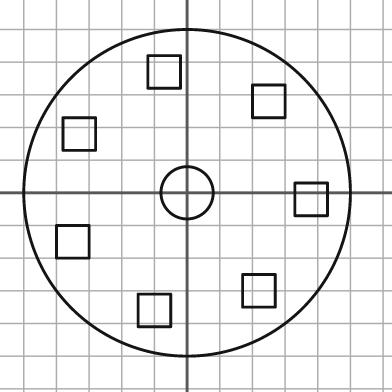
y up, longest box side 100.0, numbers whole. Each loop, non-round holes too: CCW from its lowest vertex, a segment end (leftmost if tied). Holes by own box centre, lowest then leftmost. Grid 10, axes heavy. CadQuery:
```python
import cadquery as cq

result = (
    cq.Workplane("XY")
    .moveTo(0.0, 0.0)
    .circle(50.0)
    .moveTo(-15.0, -41.0)
    .lineTo(-5.0, -41.0)
    .lineTo(-5.0, -31.0)
    .lineTo(-15.0, -31.0)
    .close()
    .moveTo(17.0, -35.0)
    .lineTo(27.0, -35.0)
    .lineTo(27.0, -25.0)
    .lineTo(17.0, -25.0)
    .close()
    .moveTo(-40.0, -20.0)
    .lineTo(-30.0, -20.0)
    .lineTo(-30.0, -10.0)
    .lineTo(-40.0, -10.0)
    .close()
    .moveTo(33.0, -7.0)
    .lineTo(43.0, -7.0)
    .lineTo(43.0, 3.0)
    .lineTo(33.0, 3.0)
    .close()
    .moveTo(0.0, 0.0)
    .circle(8.0)
    .moveTo(-38.0, 13.0)
    .lineTo(-28.0, 13.0)
    .lineTo(-28.0, 23.0)
    .lineTo(-38.0, 23.0)
    .close()
    .moveTo(20.0, 23.0)
    .lineTo(30.0, 23.0)
    .lineTo(30.0, 33.0)
    .lineTo(20.0, 33.0)
    .close()
    .moveTo(-12.0, 32.0)
    .lineTo(-2.0, 32.0)
    .lineTo(-2.0, 42.0)
    .lineTo(-12.0, 42.0)
    .close()
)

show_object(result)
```